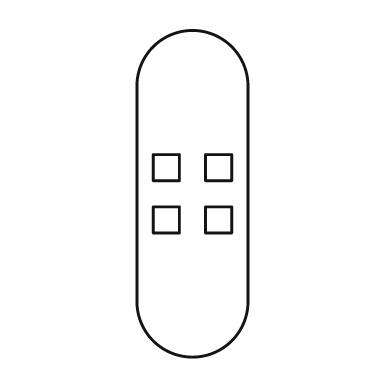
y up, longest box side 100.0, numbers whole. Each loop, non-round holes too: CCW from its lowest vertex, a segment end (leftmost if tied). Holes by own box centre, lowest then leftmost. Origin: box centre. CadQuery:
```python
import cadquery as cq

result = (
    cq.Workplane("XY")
    .moveTo(-17.0, -33.0)
    .threePointArc((0.0, -50.0), (17.0, -33.0))
    .lineTo(17.0, 33.0)
    .threePointArc((0.0, 50.0), (-17.0, 33.0))
    .close()
    .moveTo(-12.0, -12.0)
    .lineTo(-4.0, -12.0)
    .lineTo(-4.0, -4.0)
    .lineTo(-12.0, -4.0)
    .close()
    .moveTo(4.0, -12.0)
    .lineTo(12.0, -12.0)
    .lineTo(12.0, -4.0)
    .lineTo(4.0, -4.0)
    .close()
    .moveTo(-12.0, 4.0)
    .lineTo(-4.0, 4.0)
    .lineTo(-4.0, 12.0)
    .lineTo(-12.0, 12.0)
    .close()
    .moveTo(4.0, 4.0)
    .lineTo(12.0, 4.0)
    .lineTo(12.0, 12.0)
    .lineTo(4.0, 12.0)
    .close()
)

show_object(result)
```